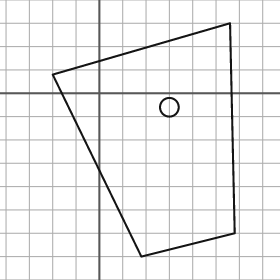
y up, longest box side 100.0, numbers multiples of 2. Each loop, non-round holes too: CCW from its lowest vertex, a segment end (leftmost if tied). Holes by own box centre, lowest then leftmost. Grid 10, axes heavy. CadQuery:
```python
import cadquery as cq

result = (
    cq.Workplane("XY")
    .moveTo(18.0, -70.0)
    .lineTo(58.0, -60.0)
    .lineTo(56.0, 30.0)
    .lineTo(-20.0, 8.0)
    .close()
    .moveTo(30.0, -6.0)
    .circle(4.0)
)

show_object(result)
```